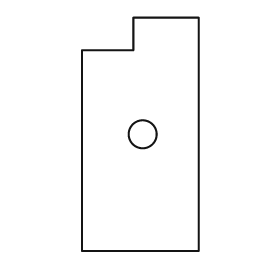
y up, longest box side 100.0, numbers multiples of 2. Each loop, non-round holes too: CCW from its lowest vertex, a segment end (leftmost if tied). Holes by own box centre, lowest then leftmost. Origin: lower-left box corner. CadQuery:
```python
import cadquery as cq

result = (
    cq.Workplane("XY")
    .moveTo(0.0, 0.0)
    .lineTo(50.0, 0.0)
    .lineTo(50.0, 100.0)
    .lineTo(22.0, 100.0)
    .lineTo(22.0, 86.0)
    .lineTo(0.0, 86.0)
    .close()
    .moveTo(26.0, 50.0)
    .circle(6.0)
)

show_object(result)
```